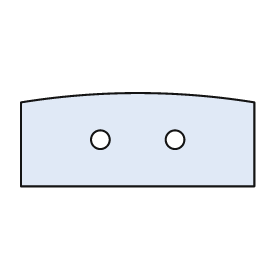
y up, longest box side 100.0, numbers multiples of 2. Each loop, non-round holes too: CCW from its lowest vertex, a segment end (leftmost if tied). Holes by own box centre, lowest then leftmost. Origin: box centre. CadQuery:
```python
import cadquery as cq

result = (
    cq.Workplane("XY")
    .moveTo(-50.0, -20.0)
    .lineTo(50.0, -20.0)
    .lineTo(50.0, 16.0)
    .threePointArc((0.0, 20.0), (-50.0, 16.0))
    .close()
    .moveTo(-16.0, 0.0)
    .circle(4.0)
    .moveTo(16.0, 0.0)
    .circle(4.0)
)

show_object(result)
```